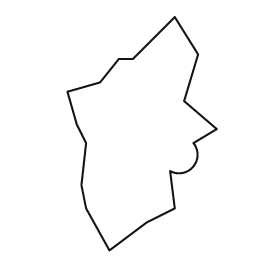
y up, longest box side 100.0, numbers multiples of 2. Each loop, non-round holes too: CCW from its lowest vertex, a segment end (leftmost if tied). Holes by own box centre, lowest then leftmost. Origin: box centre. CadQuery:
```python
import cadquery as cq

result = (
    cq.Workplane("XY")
    .moveTo(-14.0, -50.0)
    .lineTo(2.0, -38.0)
    .lineTo(14.0, -32.0)
    .lineTo(12.0, -16.0)
    .threePointArc((22.0, -14.0), (22.0, -4.0))
    .lineTo(32.0, 2.0)
    .lineTo(18.0, 14.0)
    .lineTo(24.0, 34.0)
    .lineTo(14.0, 50.0)
    .lineTo(-4.0, 32.0)
    .lineTo(-10.0, 32.0)
    .lineTo(-18.0, 22.0)
    .lineTo(-32.0, 18.0)
    .lineTo(-28.0, 4.0)
    .lineTo(-24.0, -4.0)
    .lineTo(-26.0, -22.0)
    .lineTo(-24.0, -32.0)
    .close()
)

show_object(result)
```